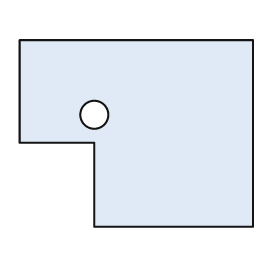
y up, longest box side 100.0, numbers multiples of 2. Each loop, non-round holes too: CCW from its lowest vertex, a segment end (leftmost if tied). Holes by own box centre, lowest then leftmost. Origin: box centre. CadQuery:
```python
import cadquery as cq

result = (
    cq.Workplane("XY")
    .moveTo(-18.0, -40.0)
    .lineTo(50.0, -40.0)
    .lineTo(50.0, 40.0)
    .lineTo(-50.0, 40.0)
    .lineTo(-50.0, -4.0)
    .lineTo(-18.0, -4.0)
    .close()
    .moveTo(-18.0, 8.0)
    .circle(6.0)
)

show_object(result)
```